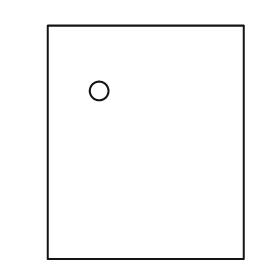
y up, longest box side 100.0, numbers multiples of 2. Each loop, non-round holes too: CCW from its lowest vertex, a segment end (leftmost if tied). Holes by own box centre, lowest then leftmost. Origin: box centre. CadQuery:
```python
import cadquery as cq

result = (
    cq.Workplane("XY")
    .moveTo(-42.0, -50.0)
    .lineTo(42.0, -50.0)
    .lineTo(42.0, 50.0)
    .lineTo(-42.0, 50.0)
    .close()
    .moveTo(-20.0, 22.0)
    .circle(4.0)
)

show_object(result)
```